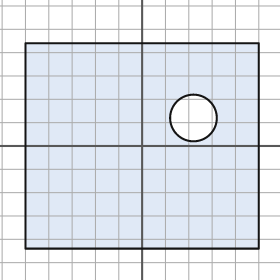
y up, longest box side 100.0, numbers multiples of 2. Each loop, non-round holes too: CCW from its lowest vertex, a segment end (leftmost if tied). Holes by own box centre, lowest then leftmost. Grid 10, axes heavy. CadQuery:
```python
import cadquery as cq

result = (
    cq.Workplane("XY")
    .moveTo(-50.0, -44.0)
    .lineTo(50.0, -44.0)
    .lineTo(50.0, 44.0)
    .lineTo(-50.0, 44.0)
    .close()
    .moveTo(22.0, 12.0)
    .circle(10.0)
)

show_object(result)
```